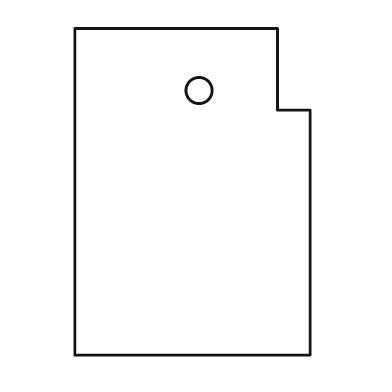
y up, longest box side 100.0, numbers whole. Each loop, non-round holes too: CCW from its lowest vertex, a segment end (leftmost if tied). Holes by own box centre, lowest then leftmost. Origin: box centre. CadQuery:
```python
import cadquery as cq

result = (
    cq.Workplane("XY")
    .moveTo(-36.0, -50.0)
    .lineTo(36.0, -50.0)
    .lineTo(36.0, 25.0)
    .lineTo(26.0, 25.0)
    .lineTo(26.0, 50.0)
    .lineTo(-36.0, 50.0)
    .close()
    .moveTo(2.0, 31.0)
    .circle(4.0)
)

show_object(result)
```